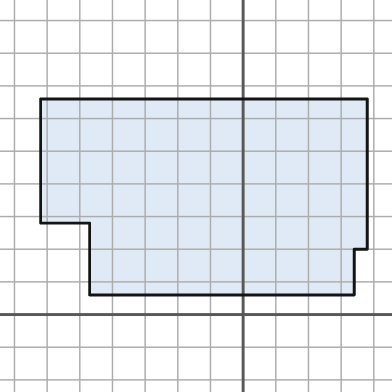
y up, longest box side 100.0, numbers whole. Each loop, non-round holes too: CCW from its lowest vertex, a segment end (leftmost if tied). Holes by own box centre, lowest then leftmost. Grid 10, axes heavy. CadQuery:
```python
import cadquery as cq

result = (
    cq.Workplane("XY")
    .moveTo(-47.0, 6.0)
    .lineTo(34.0, 6.0)
    .lineTo(34.0, 20.0)
    .lineTo(38.0, 20.0)
    .lineTo(38.0, 66.0)
    .lineTo(-62.0, 66.0)
    .lineTo(-62.0, 28.0)
    .lineTo(-47.0, 28.0)
    .close()
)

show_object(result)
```